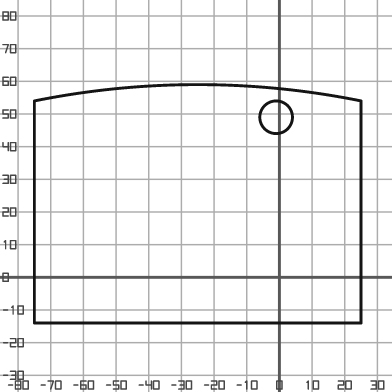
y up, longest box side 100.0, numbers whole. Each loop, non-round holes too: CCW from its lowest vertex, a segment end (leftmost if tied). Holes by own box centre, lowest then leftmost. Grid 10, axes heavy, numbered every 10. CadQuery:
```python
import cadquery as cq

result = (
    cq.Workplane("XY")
    .moveTo(-75.0, -14.0)
    .lineTo(25.0, -14.0)
    .lineTo(25.0, 54.0)
    .threePointArc((-25.0, 59.0), (-75.0, 54.0))
    .close()
    .moveTo(-1.0, 49.0)
    .circle(5.0)
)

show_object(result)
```